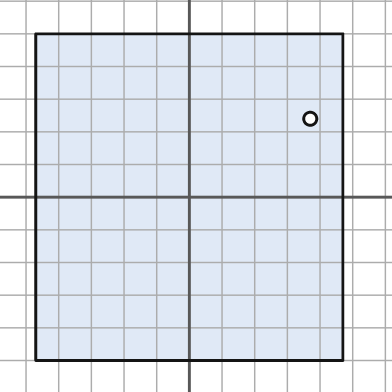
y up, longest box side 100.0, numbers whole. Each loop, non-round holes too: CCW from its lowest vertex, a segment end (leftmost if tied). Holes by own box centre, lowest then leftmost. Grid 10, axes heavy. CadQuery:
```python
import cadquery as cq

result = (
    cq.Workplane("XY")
    .moveTo(-47.0, -50.0)
    .lineTo(47.0, -50.0)
    .lineTo(47.0, 50.0)
    .lineTo(-47.0, 50.0)
    .close()
    .moveTo(37.0, 24.0)
    .circle(2.0)
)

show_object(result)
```